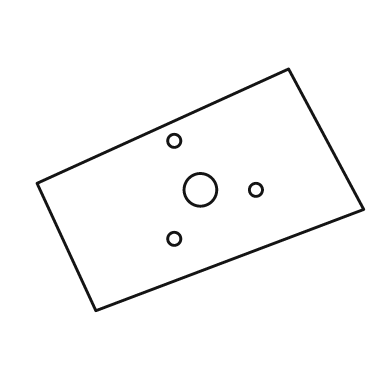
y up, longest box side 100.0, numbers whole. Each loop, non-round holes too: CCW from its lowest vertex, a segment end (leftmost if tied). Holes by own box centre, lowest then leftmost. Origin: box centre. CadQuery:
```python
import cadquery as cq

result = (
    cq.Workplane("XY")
    .moveTo(-32.0, -37.0)
    .lineTo(50.0, -6.0)
    .lineTo(27.0, 37.0)
    .lineTo(-50.0, 2.0)
    .close()
    .moveTo(-8.0, -15.0)
    .circle(2.0)
    .moveTo(0.0, 0.0)
    .circle(5.0)
    .moveTo(17.0, 0.0)
    .circle(2.0)
    .moveTo(-8.0, 15.0)
    .circle(2.0)
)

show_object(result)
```